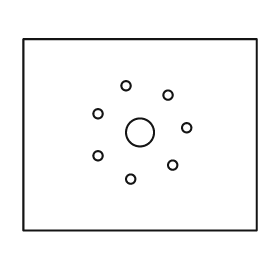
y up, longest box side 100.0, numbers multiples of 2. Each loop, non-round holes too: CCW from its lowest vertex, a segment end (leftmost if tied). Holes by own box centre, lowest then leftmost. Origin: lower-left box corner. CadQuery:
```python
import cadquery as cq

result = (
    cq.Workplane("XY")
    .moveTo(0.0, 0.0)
    .lineTo(100.0, 0.0)
    .lineTo(100.0, 82.0)
    .lineTo(0.0, 82.0)
    .close()
    .moveTo(46.0, 22.0)
    .circle(2.0)
    .moveTo(64.0, 28.0)
    .circle(2.0)
    .moveTo(32.0, 32.0)
    .circle(2.0)
    .moveTo(50.0, 42.0)
    .circle(6.0)
    .moveTo(70.0, 44.0)
    .circle(2.0)
    .moveTo(32.0, 50.0)
    .circle(2.0)
    .moveTo(62.0, 58.0)
    .circle(2.0)
    .moveTo(44.0, 62.0)
    .circle(2.0)
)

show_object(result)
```